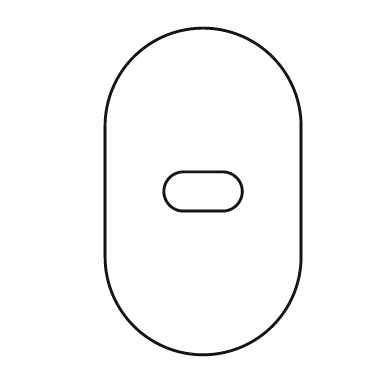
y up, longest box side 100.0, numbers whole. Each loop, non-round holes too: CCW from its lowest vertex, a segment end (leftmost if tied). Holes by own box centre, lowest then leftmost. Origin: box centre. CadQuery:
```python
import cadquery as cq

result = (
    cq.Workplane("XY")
    .moveTo(-30.0, -20.0)
    .threePointArc((0.0, -50.0), (30.0, -20.0))
    .lineTo(30.0, 20.0)
    .threePointArc((0.0, 50.0), (-30.0, 20.0))
    .close()
    .moveTo(-6.0, -6.0)
    .lineTo(6.0, -6.0)
    .threePointArc((12.0, 0.0), (6.0, 6.0))
    .lineTo(-6.0, 6.0)
    .threePointArc((-12.0, 0.0), (-6.0, -6.0))
    .close()
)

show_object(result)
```